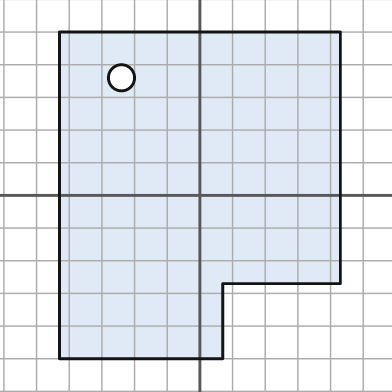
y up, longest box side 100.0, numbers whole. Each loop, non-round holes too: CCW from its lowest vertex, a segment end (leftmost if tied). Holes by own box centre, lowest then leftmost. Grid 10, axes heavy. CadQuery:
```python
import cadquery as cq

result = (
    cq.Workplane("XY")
    .moveTo(-43.0, -50.0)
    .lineTo(7.0, -50.0)
    .lineTo(7.0, -27.0)
    .lineTo(43.0, -27.0)
    .lineTo(43.0, 50.0)
    .lineTo(-43.0, 50.0)
    .close()
    .moveTo(-24.0, 36.0)
    .circle(4.0)
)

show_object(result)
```